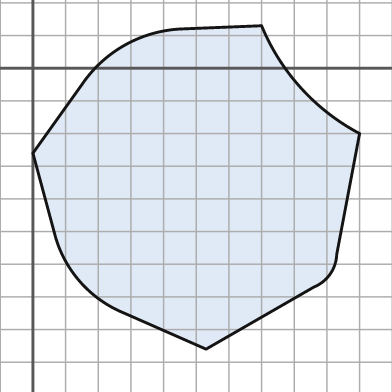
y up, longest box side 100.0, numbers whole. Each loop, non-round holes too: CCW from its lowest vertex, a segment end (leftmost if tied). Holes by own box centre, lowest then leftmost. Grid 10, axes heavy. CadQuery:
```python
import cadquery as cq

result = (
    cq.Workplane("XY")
    .moveTo(53.0, -86.0)
    .lineTo(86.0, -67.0)
    .threePointArc((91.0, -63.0), (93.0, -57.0))
    .lineTo(100.0, -20.0)
    .threePointArc((82.0, -6.0), (70.0, 13.0))
    .lineTo(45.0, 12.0)
    .threePointArc((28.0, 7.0), (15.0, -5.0))
    .lineTo(0.0, -26.0)
    .lineTo(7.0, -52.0)
    .threePointArc((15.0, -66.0), (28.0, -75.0))
    .close()
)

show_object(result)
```